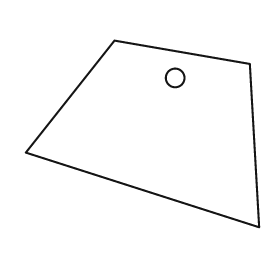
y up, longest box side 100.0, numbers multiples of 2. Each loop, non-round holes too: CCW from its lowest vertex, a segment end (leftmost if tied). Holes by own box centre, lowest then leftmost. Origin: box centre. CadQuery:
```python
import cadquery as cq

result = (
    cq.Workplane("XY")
    .moveTo(50.0, -40.0)
    .lineTo(46.0, 30.0)
    .lineTo(-12.0, 40.0)
    .lineTo(-50.0, -8.0)
    .close()
    .moveTo(14.0, 24.0)
    .circle(4.0)
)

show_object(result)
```